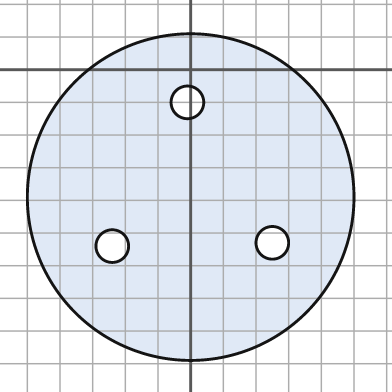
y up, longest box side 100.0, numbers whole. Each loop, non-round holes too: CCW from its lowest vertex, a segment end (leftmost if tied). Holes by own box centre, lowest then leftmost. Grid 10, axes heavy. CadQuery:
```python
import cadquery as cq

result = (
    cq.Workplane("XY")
    .moveTo(0.0, -39.0)
    .circle(50.0)
    .moveTo(-24.0, -54.0)
    .circle(5.0)
    .moveTo(25.0, -53.0)
    .circle(5.0)
    .moveTo(-1.0, -10.0)
    .circle(5.0)
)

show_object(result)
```